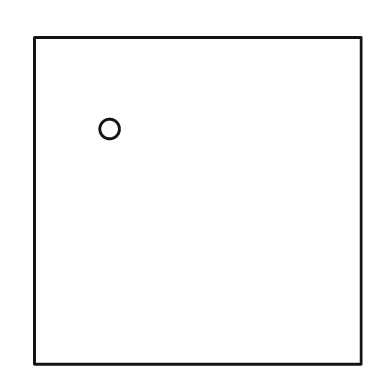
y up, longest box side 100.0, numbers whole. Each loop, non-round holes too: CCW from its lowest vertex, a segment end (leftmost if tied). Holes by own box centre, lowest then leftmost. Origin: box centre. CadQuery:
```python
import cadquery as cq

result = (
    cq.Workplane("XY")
    .moveTo(-50.0, -50.0)
    .lineTo(50.0, -50.0)
    .lineTo(50.0, 50.0)
    .lineTo(-50.0, 50.0)
    .close()
    .moveTo(-27.0, 22.0)
    .circle(3.0)
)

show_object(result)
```